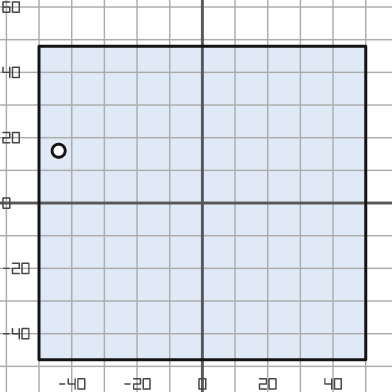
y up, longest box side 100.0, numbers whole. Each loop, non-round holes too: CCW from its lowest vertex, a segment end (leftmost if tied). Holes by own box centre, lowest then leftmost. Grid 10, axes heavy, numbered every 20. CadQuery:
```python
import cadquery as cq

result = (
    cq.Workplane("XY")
    .moveTo(-50.0, -48.0)
    .lineTo(50.0, -48.0)
    .lineTo(50.0, 48.0)
    .lineTo(-50.0, 48.0)
    .close()
    .moveTo(-44.0, 16.0)
    .circle(2.0)
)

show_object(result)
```